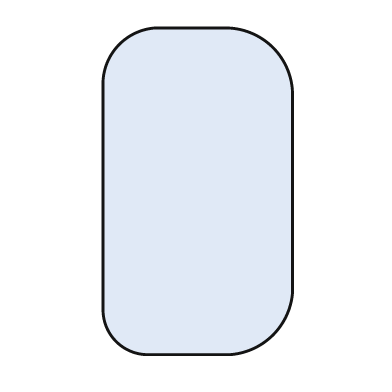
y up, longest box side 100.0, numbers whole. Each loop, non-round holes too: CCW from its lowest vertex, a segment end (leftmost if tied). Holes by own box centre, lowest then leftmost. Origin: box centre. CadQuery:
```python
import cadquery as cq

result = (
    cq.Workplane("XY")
    .moveTo(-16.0, -50.0)
    .lineTo(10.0, -50.0)
    .threePointArc((23.0, -44.0), (29.0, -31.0))
    .lineTo(29.0, 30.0)
    .threePointArc((23.0, 44.0), (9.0, 50.0))
    .lineTo(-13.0, 50.0)
    .threePointArc((-24.0, 45.0), (-29.0, 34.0))
    .lineTo(-29.0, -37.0)
    .threePointArc((-25.0, -46.0), (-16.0, -50.0))
    .close()
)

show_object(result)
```